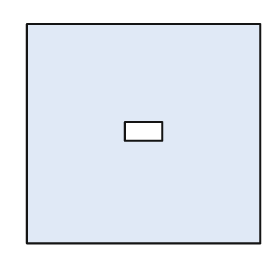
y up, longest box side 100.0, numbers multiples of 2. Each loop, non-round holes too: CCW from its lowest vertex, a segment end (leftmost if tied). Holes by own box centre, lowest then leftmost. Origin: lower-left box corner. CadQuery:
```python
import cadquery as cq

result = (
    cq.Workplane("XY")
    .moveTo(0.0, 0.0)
    .lineTo(100.0, 0.0)
    .lineTo(100.0, 94.0)
    .lineTo(0.0, 94.0)
    .close()
    .moveTo(42.0, 44.0)
    .lineTo(58.0, 44.0)
    .lineTo(58.0, 52.0)
    .lineTo(42.0, 52.0)
    .close()
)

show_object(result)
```